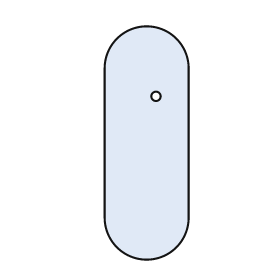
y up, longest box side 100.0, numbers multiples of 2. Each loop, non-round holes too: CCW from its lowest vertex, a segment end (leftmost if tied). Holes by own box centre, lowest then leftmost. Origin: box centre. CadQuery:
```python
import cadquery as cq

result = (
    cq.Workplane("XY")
    .moveTo(-18.0, -32.0)
    .threePointArc((0.0, -50.0), (18.0, -32.0))
    .lineTo(18.0, 32.0)
    .threePointArc((0.0, 50.0), (-18.0, 32.0))
    .close()
    .moveTo(4.0, 20.0)
    .circle(2.0)
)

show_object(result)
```